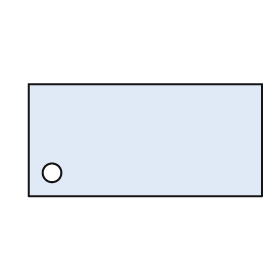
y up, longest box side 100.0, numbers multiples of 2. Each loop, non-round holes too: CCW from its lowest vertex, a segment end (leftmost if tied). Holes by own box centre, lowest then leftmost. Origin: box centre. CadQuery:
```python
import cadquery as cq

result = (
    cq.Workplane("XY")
    .moveTo(-50.0, -24.0)
    .lineTo(50.0, -24.0)
    .lineTo(50.0, 24.0)
    .lineTo(-50.0, 24.0)
    .close()
    .moveTo(-40.0, -14.0)
    .circle(4.0)
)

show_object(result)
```